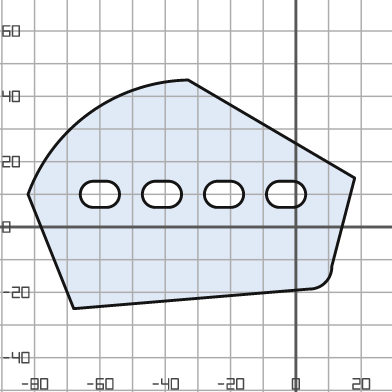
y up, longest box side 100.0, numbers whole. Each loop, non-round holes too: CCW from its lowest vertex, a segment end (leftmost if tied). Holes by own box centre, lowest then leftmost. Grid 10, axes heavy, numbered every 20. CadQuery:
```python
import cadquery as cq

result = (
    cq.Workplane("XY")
    .moveTo(-68.0, -25.0)
    .lineTo(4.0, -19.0)
    .threePointArc((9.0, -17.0), (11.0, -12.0))
    .lineTo(18.0, 15.0)
    .lineTo(-33.0, 45.0)
    .threePointArc((-63.0, 35.0), (-82.0, 10.0))
    .close()
    .moveTo(-62.0, 6.0)
    .lineTo(-58.0, 6.0)
    .threePointArc((-54.0, 10.0), (-58.0, 14.0))
    .lineTo(-62.0, 14.0)
    .threePointArc((-66.0, 10.0), (-62.0, 6.0))
    .close()
    .moveTo(-43.0, 6.0)
    .lineTo(-39.0, 6.0)
    .threePointArc((-35.0, 10.0), (-39.0, 14.0))
    .lineTo(-43.0, 14.0)
    .threePointArc((-47.0, 10.0), (-43.0, 6.0))
    .close()
    .moveTo(-24.0, 6.0)
    .lineTo(-20.0, 6.0)
    .threePointArc((-16.0, 10.0), (-20.0, 14.0))
    .lineTo(-24.0, 14.0)
    .threePointArc((-28.0, 10.0), (-24.0, 6.0))
    .close()
    .moveTo(-5.0, 6.0)
    .lineTo(-1.0, 6.0)
    .threePointArc((3.0, 10.0), (-1.0, 14.0))
    .lineTo(-5.0, 14.0)
    .threePointArc((-9.0, 10.0), (-5.0, 6.0))
    .close()
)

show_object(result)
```